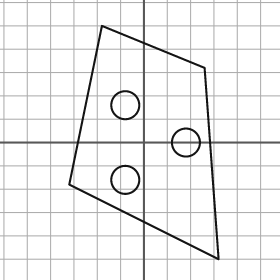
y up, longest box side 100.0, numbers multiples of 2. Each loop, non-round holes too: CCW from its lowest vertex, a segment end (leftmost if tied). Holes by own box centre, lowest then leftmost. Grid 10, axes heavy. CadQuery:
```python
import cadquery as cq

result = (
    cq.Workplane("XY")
    .moveTo(32.0, -50.0)
    .lineTo(26.0, 32.0)
    .lineTo(-18.0, 50.0)
    .lineTo(-32.0, -18.0)
    .close()
    .moveTo(-8.0, -16.0)
    .circle(6.0)
    .moveTo(18.0, 0.0)
    .circle(6.0)
    .moveTo(-8.0, 16.0)
    .circle(6.0)
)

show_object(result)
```